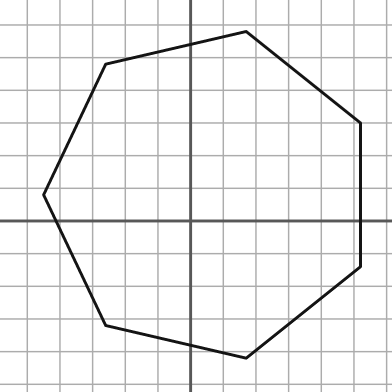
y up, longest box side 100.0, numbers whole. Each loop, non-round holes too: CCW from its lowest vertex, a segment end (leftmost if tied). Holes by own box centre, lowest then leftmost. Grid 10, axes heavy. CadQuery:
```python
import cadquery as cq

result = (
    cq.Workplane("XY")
    .moveTo(17.0, -42.0)
    .lineTo(52.0, -14.0)
    .lineTo(52.0, 30.0)
    .lineTo(17.0, 58.0)
    .lineTo(-26.0, 48.0)
    .lineTo(-45.0, 8.0)
    .lineTo(-26.0, -32.0)
    .close()
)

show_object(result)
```